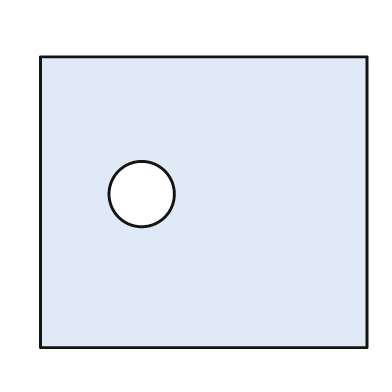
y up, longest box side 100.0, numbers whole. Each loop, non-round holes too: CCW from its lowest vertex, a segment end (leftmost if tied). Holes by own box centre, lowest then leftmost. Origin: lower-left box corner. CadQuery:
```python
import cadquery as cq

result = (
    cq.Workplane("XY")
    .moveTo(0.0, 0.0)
    .lineTo(100.0, 0.0)
    .lineTo(100.0, 89.0)
    .lineTo(0.0, 89.0)
    .close()
    .moveTo(31.0, 47.0)
    .circle(10.0)
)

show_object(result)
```